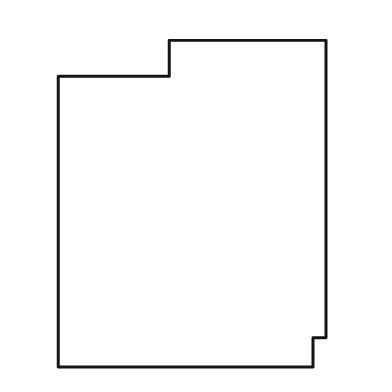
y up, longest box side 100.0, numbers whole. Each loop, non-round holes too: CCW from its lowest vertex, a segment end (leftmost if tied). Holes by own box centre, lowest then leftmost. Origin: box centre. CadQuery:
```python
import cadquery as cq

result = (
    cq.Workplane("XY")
    .moveTo(-41.0, -50.0)
    .lineTo(37.0, -50.0)
    .lineTo(37.0, -41.0)
    .lineTo(41.0, -41.0)
    .lineTo(41.0, 50.0)
    .lineTo(-7.0, 50.0)
    .lineTo(-7.0, 39.0)
    .lineTo(-41.0, 39.0)
    .close()
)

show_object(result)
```